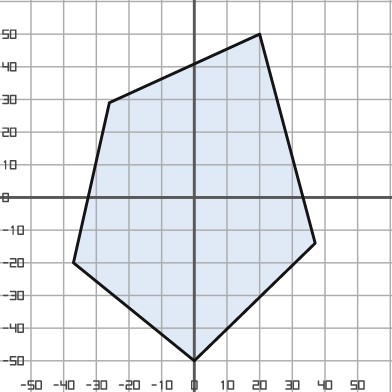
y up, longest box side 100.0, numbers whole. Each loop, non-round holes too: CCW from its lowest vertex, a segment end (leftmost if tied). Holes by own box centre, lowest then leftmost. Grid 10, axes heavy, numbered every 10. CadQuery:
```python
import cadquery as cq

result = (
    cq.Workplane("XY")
    .moveTo(0.0, -50.0)
    .lineTo(37.0, -14.0)
    .lineTo(20.0, 50.0)
    .lineTo(-26.0, 29.0)
    .lineTo(-37.0, -20.0)
    .close()
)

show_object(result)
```